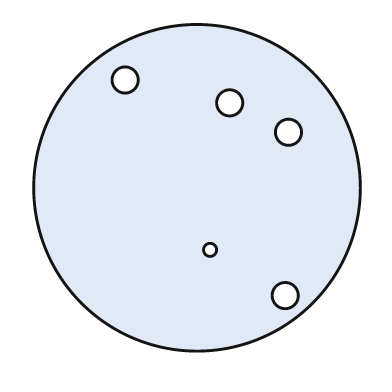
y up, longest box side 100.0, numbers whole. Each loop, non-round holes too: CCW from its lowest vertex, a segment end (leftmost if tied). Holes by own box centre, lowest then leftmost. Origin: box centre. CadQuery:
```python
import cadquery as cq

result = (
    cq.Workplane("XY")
    .moveTo(0.0, 0.0)
    .circle(50.0)
    .moveTo(27.0, -33.0)
    .circle(4.0)
    .moveTo(4.0, -19.0)
    .circle(2.0)
    .moveTo(28.0, 17.0)
    .circle(4.0)
    .moveTo(10.0, 26.0)
    .circle(4.0)
    .moveTo(-22.0, 33.0)
    .circle(4.0)
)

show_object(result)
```